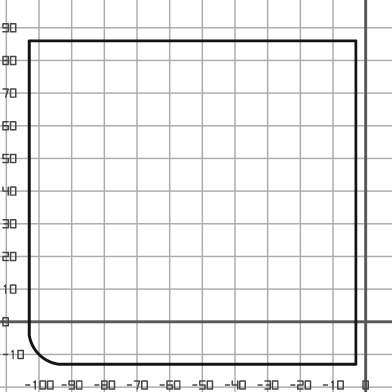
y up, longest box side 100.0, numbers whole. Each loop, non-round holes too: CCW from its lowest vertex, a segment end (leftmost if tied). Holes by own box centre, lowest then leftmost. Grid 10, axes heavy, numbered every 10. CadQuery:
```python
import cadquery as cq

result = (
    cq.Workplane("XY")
    .moveTo(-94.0, -13.0)
    .lineTo(-3.0, -13.0)
    .lineTo(-3.0, 86.0)
    .lineTo(-103.0, 86.0)
    .lineTo(-103.0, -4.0)
    .threePointArc((-100.0, -10.0), (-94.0, -13.0))
    .close()
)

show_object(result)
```